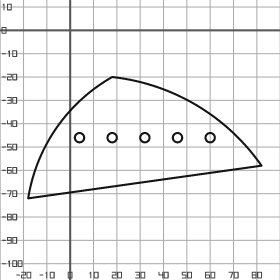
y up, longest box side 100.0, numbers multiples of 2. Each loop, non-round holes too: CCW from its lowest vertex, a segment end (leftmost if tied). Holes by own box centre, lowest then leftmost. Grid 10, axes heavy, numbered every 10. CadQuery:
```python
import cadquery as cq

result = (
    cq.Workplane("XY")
    .moveTo(-18.0, -72.0)
    .lineTo(82.0, -58.0)
    .threePointArc((54.0, -32.0), (18.0, -20.0))
    .threePointArc((-6.0, -42.0), (-18.0, -72.0))
    .close()
    .moveTo(4.0, -46.0)
    .circle(2.0)
    .moveTo(18.0, -46.0)
    .circle(2.0)
    .moveTo(32.0, -46.0)
    .circle(2.0)
    .moveTo(46.0, -46.0)
    .circle(2.0)
    .moveTo(60.0, -46.0)
    .circle(2.0)
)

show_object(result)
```